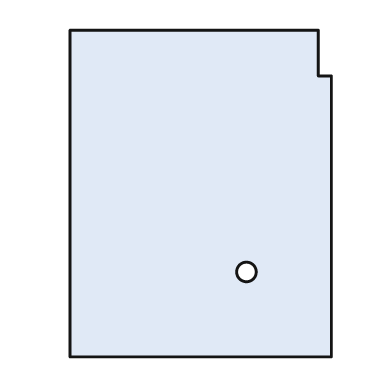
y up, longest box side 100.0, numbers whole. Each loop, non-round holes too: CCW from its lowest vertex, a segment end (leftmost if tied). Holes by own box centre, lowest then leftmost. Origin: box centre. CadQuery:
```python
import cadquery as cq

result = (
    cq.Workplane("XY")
    .moveTo(-40.0, -50.0)
    .lineTo(40.0, -50.0)
    .lineTo(40.0, 36.0)
    .lineTo(36.0, 36.0)
    .lineTo(36.0, 50.0)
    .lineTo(-40.0, 50.0)
    .close()
    .moveTo(14.0, -24.0)
    .circle(3.0)
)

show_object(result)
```